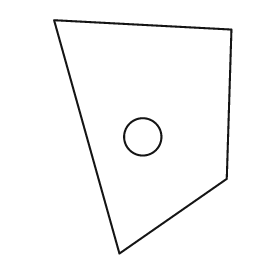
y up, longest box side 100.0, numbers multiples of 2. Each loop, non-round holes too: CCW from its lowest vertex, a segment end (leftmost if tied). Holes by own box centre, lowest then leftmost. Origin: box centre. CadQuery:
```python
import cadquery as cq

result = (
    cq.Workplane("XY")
    .moveTo(-10.0, -50.0)
    .lineTo(36.0, -18.0)
    .lineTo(38.0, 46.0)
    .lineTo(-38.0, 50.0)
    .close()
    .moveTo(0.0, 0.0)
    .circle(8.0)
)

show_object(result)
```